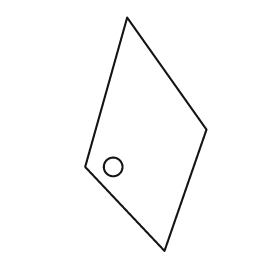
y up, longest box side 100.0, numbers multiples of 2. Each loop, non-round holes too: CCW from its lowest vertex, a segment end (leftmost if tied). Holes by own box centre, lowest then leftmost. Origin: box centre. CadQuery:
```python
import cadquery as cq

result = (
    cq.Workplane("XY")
    .moveTo(8.0, -50.0)
    .lineTo(26.0, 2.0)
    .lineTo(-8.0, 50.0)
    .lineTo(-26.0, -14.0)
    .close()
    .moveTo(-14.0, -14.0)
    .circle(4.0)
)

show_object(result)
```